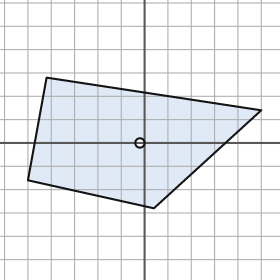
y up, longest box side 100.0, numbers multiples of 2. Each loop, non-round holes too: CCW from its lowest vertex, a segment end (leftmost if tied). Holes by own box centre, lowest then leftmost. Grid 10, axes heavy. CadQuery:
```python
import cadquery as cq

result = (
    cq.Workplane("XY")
    .moveTo(4.0, -28.0)
    .lineTo(50.0, 14.0)
    .lineTo(-42.0, 28.0)
    .lineTo(-50.0, -16.0)
    .close()
    .moveTo(-2.0, 0.0)
    .circle(2.0)
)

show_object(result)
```